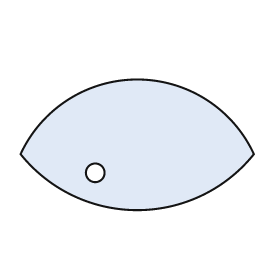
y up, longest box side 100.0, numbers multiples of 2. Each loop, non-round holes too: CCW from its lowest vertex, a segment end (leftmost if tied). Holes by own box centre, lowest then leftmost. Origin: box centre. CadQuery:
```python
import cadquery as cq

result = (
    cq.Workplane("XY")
    .moveTo(-50.0, -4.0)
    .threePointArc((0.0, -28.0), (50.0, -4.0))
    .threePointArc((0.0, 28.0), (-50.0, -4.0))
    .close()
    .moveTo(-18.0, -12.0)
    .circle(4.0)
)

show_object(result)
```